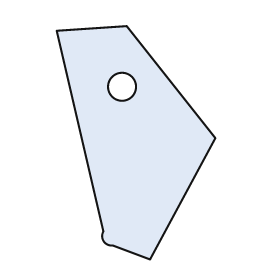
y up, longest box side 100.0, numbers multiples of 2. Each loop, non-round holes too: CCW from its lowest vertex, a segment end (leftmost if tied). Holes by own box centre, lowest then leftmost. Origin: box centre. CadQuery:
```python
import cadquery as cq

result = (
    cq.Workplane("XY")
    .moveTo(6.0, -50.0)
    .lineTo(34.0, 2.0)
    .lineTo(-4.0, 50.0)
    .lineTo(-34.0, 48.0)
    .lineTo(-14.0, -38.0)
    .threePointArc((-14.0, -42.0), (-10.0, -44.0))
    .close()
    .moveTo(-6.0, 24.0)
    .circle(6.0)
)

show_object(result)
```